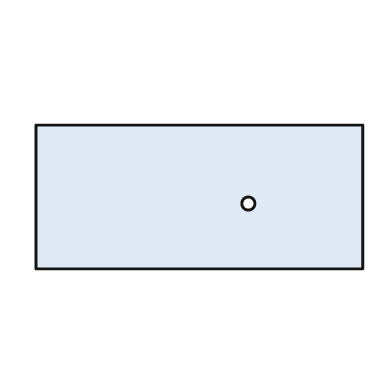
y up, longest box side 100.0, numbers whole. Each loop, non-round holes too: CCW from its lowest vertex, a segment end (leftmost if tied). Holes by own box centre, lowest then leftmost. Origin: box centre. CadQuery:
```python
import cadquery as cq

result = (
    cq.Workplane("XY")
    .moveTo(-50.0, -22.0)
    .lineTo(50.0, -22.0)
    .lineTo(50.0, 22.0)
    .lineTo(-50.0, 22.0)
    .close()
    .moveTo(15.0, -2.0)
    .circle(2.0)
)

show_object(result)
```